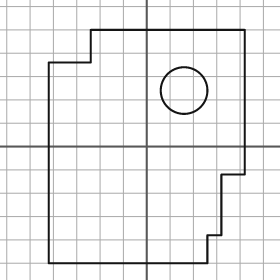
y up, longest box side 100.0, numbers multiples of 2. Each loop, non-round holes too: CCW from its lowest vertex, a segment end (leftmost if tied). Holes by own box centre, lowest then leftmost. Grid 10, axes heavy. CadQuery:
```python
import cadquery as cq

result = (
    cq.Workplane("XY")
    .moveTo(-42.0, -50.0)
    .lineTo(26.0, -50.0)
    .lineTo(26.0, -38.0)
    .lineTo(32.0, -38.0)
    .lineTo(32.0, -12.0)
    .lineTo(42.0, -12.0)
    .lineTo(42.0, 50.0)
    .lineTo(-24.0, 50.0)
    .lineTo(-24.0, 36.0)
    .lineTo(-42.0, 36.0)
    .close()
    .moveTo(16.0, 24.0)
    .circle(10.0)
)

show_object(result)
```